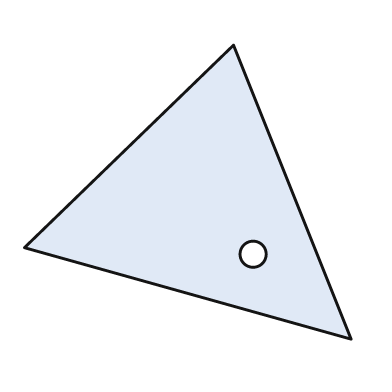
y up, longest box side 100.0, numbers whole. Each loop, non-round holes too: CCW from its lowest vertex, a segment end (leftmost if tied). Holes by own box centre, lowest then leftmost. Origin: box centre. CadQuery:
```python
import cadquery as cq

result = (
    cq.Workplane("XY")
    .moveTo(50.0, -45.0)
    .lineTo(14.0, 45.0)
    .lineTo(-50.0, -17.0)
    .close()
    .moveTo(20.0, -19.0)
    .circle(4.0)
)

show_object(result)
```